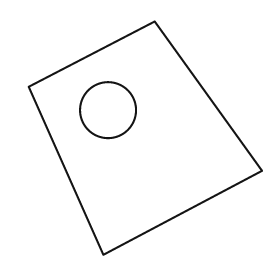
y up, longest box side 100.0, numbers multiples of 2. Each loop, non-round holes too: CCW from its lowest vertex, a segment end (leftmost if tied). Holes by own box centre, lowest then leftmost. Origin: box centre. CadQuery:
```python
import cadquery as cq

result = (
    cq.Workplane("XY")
    .moveTo(-18.0, -50.0)
    .lineTo(50.0, -14.0)
    .lineTo(4.0, 50.0)
    .lineTo(-50.0, 22.0)
    .close()
    .moveTo(-16.0, 12.0)
    .circle(12.0)
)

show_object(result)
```